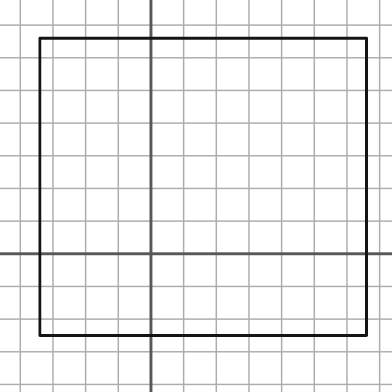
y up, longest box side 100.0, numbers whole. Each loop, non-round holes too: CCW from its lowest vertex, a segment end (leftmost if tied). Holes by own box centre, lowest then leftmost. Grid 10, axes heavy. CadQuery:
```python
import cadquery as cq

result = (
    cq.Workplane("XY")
    .moveTo(-34.0, -25.0)
    .lineTo(66.0, -25.0)
    .lineTo(66.0, 66.0)
    .lineTo(-34.0, 66.0)
    .close()
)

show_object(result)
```